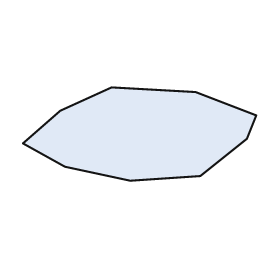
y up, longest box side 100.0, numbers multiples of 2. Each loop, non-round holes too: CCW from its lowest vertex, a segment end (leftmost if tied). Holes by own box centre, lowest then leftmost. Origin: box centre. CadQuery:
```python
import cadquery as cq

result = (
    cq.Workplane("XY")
    .moveTo(-4.0, -20.0)
    .lineTo(26.0, -18.0)
    .lineTo(46.0, -2.0)
    .lineTo(50.0, 8.0)
    .lineTo(24.0, 18.0)
    .lineTo(-12.0, 20.0)
    .lineTo(-34.0, 10.0)
    .lineTo(-50.0, -4.0)
    .lineTo(-32.0, -14.0)
    .close()
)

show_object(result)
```